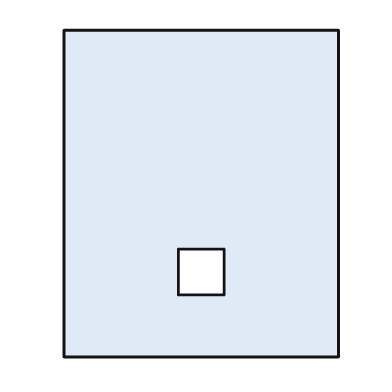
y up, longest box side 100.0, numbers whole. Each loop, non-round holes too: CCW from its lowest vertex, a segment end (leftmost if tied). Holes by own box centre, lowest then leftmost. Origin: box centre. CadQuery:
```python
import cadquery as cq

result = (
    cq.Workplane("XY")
    .moveTo(-42.0, -50.0)
    .lineTo(42.0, -50.0)
    .lineTo(42.0, 50.0)
    .lineTo(-42.0, 50.0)
    .close()
    .moveTo(-7.0, -31.0)
    .lineTo(7.0, -31.0)
    .lineTo(7.0, -17.0)
    .lineTo(-7.0, -17.0)
    .close()
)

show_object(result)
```